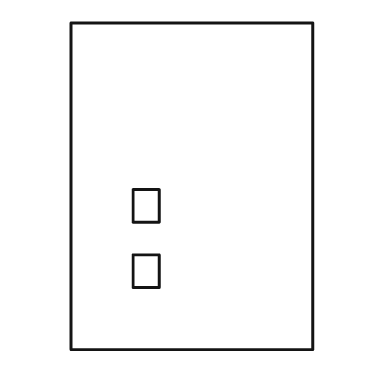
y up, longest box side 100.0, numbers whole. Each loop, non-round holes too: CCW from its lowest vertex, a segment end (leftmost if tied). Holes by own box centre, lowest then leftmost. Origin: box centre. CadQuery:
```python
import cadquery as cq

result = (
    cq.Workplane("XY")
    .moveTo(-37.0, -50.0)
    .lineTo(37.0, -50.0)
    .lineTo(37.0, 50.0)
    .lineTo(-37.0, 50.0)
    .close()
    .moveTo(-18.0, -31.0)
    .lineTo(-10.0, -31.0)
    .lineTo(-10.0, -21.0)
    .lineTo(-18.0, -21.0)
    .close()
    .moveTo(-18.0, -11.0)
    .lineTo(-10.0, -11.0)
    .lineTo(-10.0, -1.0)
    .lineTo(-18.0, -1.0)
    .close()
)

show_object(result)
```